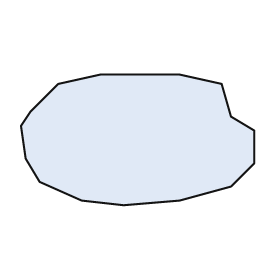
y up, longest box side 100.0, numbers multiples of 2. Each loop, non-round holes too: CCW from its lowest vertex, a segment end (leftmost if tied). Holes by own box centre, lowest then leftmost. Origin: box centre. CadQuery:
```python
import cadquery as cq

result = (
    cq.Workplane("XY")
    .moveTo(-6.0, -28.0)
    .lineTo(18.0, -26.0)
    .lineTo(40.0, -20.0)
    .lineTo(50.0, -10.0)
    .lineTo(50.0, 4.0)
    .lineTo(40.0, 10.0)
    .lineTo(36.0, 24.0)
    .lineTo(18.0, 28.0)
    .lineTo(-16.0, 28.0)
    .lineTo(-34.0, 24.0)
    .lineTo(-46.0, 12.0)
    .lineTo(-50.0, 6.0)
    .lineTo(-48.0, -8.0)
    .lineTo(-42.0, -18.0)
    .lineTo(-24.0, -26.0)
    .close()
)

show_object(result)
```